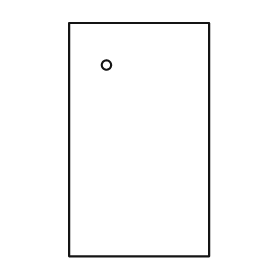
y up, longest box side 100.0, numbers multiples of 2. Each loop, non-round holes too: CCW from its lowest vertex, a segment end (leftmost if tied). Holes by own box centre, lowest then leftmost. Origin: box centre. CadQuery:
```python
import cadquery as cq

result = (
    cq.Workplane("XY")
    .moveTo(-30.0, -50.0)
    .lineTo(30.0, -50.0)
    .lineTo(30.0, 50.0)
    .lineTo(-30.0, 50.0)
    .close()
    .moveTo(-14.0, 32.0)
    .circle(2.0)
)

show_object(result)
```